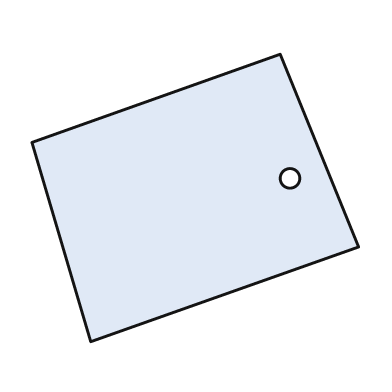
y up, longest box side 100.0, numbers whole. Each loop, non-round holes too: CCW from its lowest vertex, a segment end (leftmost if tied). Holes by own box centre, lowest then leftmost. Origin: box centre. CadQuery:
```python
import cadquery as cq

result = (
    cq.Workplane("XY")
    .moveTo(-32.0, -44.0)
    .lineTo(50.0, -15.0)
    .lineTo(26.0, 44.0)
    .lineTo(-50.0, 17.0)
    .close()
    .moveTo(29.0, 6.0)
    .circle(3.0)
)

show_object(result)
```